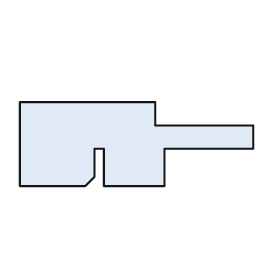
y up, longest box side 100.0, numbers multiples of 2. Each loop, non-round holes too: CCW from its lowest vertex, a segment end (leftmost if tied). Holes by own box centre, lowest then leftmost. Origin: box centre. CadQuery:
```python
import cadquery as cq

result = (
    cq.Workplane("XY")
    .moveTo(-50.0, -18.0)
    .lineTo(-22.0, -18.0)
    .lineTo(-18.0, -14.0)
    .lineTo(-18.0, -2.0)
    .lineTo(-14.0, -2.0)
    .lineTo(-14.0, -18.0)
    .lineTo(12.0, -18.0)
    .lineTo(12.0, -2.0)
    .lineTo(50.0, -2.0)
    .lineTo(50.0, 8.0)
    .lineTo(8.0, 8.0)
    .lineTo(8.0, 18.0)
    .lineTo(-50.0, 18.0)
    .close()
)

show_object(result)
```